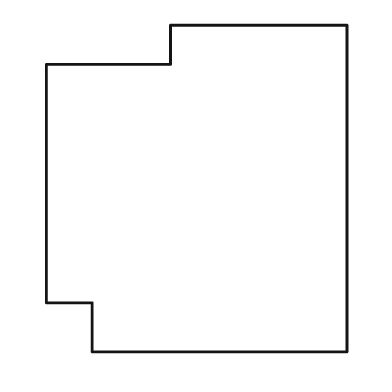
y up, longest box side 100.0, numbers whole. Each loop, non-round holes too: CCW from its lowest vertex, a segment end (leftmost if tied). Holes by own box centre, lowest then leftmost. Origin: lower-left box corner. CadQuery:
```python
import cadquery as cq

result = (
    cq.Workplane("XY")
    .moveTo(14.0, 0.0)
    .lineTo(92.0, 0.0)
    .lineTo(92.0, 100.0)
    .lineTo(38.0, 100.0)
    .lineTo(38.0, 88.0)
    .lineTo(0.0, 88.0)
    .lineTo(0.0, 15.0)
    .lineTo(14.0, 15.0)
    .close()
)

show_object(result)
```